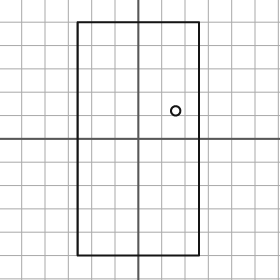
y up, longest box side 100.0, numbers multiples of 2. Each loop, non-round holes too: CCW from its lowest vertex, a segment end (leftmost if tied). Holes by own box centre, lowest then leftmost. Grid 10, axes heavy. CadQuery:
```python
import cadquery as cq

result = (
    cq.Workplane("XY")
    .moveTo(-26.0, -50.0)
    .lineTo(26.0, -50.0)
    .lineTo(26.0, 50.0)
    .lineTo(-26.0, 50.0)
    .close()
    .moveTo(16.0, 12.0)
    .circle(2.0)
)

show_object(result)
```